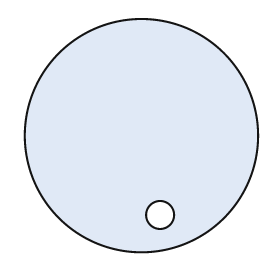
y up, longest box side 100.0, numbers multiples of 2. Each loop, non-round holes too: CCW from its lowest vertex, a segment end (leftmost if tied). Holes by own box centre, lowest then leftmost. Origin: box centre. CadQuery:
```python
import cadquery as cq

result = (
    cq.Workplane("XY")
    .moveTo(0.0, 0.0)
    .circle(50.0)
    .moveTo(8.0, -34.0)
    .circle(6.0)
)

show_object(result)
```